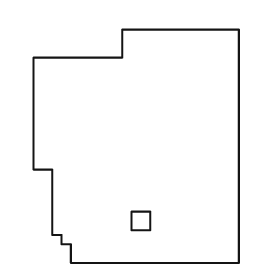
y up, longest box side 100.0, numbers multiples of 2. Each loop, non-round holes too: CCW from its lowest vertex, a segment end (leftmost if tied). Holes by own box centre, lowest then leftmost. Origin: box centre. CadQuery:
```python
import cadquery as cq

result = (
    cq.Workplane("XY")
    .moveTo(-28.0, -50.0)
    .lineTo(44.0, -50.0)
    .lineTo(44.0, 50.0)
    .lineTo(-6.0, 50.0)
    .lineTo(-6.0, 38.0)
    .lineTo(-44.0, 38.0)
    .lineTo(-44.0, -10.0)
    .lineTo(-36.0, -10.0)
    .lineTo(-36.0, -38.0)
    .lineTo(-32.0, -38.0)
    .lineTo(-32.0, -42.0)
    .lineTo(-28.0, -42.0)
    .close()
    .moveTo(-2.0, -36.0)
    .lineTo(6.0, -36.0)
    .lineTo(6.0, -28.0)
    .lineTo(-2.0, -28.0)
    .close()
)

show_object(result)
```